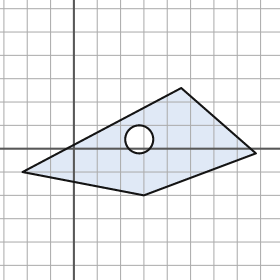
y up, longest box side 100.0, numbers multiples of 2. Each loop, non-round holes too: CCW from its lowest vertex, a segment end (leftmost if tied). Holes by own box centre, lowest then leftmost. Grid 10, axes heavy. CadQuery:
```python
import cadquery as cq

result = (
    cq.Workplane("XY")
    .moveTo(30.0, -20.0)
    .lineTo(78.0, -2.0)
    .lineTo(46.0, 26.0)
    .lineTo(-22.0, -10.0)
    .close()
    .moveTo(28.0, 4.0)
    .circle(6.0)
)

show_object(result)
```